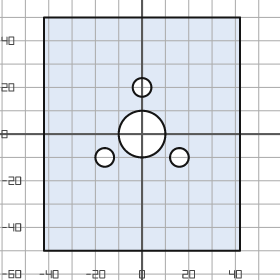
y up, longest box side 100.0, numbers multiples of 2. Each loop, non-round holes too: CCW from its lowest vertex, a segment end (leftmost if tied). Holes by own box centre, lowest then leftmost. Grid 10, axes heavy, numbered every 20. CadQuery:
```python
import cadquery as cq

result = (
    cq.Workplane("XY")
    .moveTo(-42.0, -50.0)
    .lineTo(42.0, -50.0)
    .lineTo(42.0, 50.0)
    .lineTo(-42.0, 50.0)
    .close()
    .moveTo(-16.0, -10.0)
    .circle(4.0)
    .moveTo(16.0, -10.0)
    .circle(4.0)
    .moveTo(0.0, 0.0)
    .circle(10.0)
    .moveTo(0.0, 20.0)
    .circle(4.0)
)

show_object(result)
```